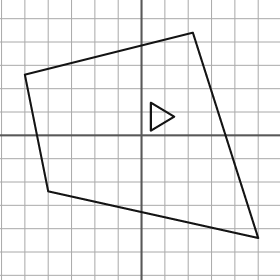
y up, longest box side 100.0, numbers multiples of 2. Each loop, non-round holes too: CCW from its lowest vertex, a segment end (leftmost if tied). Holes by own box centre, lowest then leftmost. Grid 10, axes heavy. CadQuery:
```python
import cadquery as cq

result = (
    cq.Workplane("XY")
    .moveTo(50.0, -44.0)
    .lineTo(22.0, 44.0)
    .lineTo(-50.0, 26.0)
    .lineTo(-40.0, -24.0)
    .close()
    .moveTo(4.0, 2.0)
    .lineTo(14.0, 8.0)
    .lineTo(4.0, 14.0)
    .close()
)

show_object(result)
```